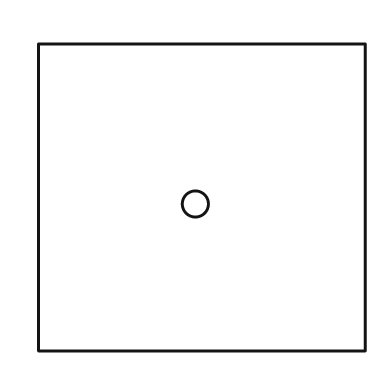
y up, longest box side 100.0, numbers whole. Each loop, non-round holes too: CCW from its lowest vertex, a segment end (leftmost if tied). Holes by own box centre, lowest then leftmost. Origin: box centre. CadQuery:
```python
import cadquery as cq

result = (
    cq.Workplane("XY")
    .moveTo(-50.0, -47.0)
    .lineTo(50.0, -47.0)
    .lineTo(50.0, 47.0)
    .lineTo(-50.0, 47.0)
    .close()
    .moveTo(-2.0, -2.0)
    .circle(4.0)
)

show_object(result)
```